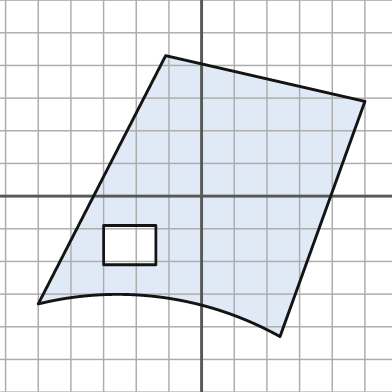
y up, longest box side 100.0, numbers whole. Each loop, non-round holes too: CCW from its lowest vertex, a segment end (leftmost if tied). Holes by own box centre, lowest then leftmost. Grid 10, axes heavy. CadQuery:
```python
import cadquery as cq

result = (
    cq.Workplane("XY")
    .moveTo(24.0, -43.0)
    .lineTo(50.0, 29.0)
    .lineTo(-11.0, 43.0)
    .lineTo(-50.0, -33.0)
    .threePointArc((-12.0, -31.0), (24.0, -43.0))
    .close()
    .moveTo(-30.0, -21.0)
    .lineTo(-14.0, -21.0)
    .lineTo(-14.0, -9.0)
    .lineTo(-30.0, -9.0)
    .close()
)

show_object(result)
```